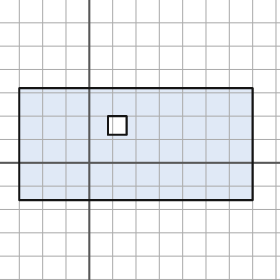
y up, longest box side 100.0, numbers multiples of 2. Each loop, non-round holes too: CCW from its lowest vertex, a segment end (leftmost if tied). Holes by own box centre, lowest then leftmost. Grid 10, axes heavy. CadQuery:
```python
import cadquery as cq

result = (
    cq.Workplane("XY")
    .moveTo(-30.0, -16.0)
    .lineTo(70.0, -16.0)
    .lineTo(70.0, 32.0)
    .lineTo(-30.0, 32.0)
    .close()
    .moveTo(8.0, 12.0)
    .lineTo(16.0, 12.0)
    .lineTo(16.0, 20.0)
    .lineTo(8.0, 20.0)
    .close()
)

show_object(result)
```